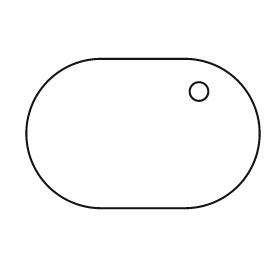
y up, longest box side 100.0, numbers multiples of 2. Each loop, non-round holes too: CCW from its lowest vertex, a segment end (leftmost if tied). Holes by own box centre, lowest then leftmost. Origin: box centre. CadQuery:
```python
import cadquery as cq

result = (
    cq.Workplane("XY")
    .moveTo(-18.0, -32.0)
    .lineTo(18.0, -32.0)
    .threePointArc((50.0, 0.0), (18.0, 32.0))
    .lineTo(-18.0, 32.0)
    .threePointArc((-50.0, 0.0), (-18.0, -32.0))
    .close()
    .moveTo(24.0, 18.0)
    .circle(4.0)
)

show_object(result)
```